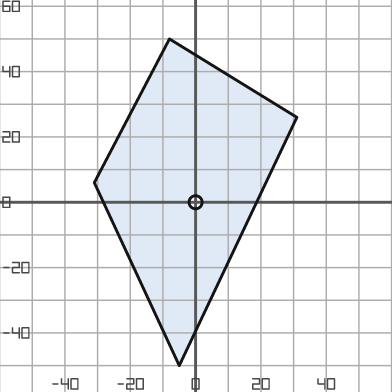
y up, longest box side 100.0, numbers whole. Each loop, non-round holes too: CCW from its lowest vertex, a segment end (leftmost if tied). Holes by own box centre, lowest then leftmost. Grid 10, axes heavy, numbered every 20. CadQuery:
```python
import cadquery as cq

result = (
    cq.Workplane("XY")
    .moveTo(-5.0, -50.0)
    .lineTo(31.0, 26.0)
    .lineTo(-8.0, 50.0)
    .lineTo(-31.0, 6.0)
    .close()
    .moveTo(0.0, 0.0)
    .circle(2.0)
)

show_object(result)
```